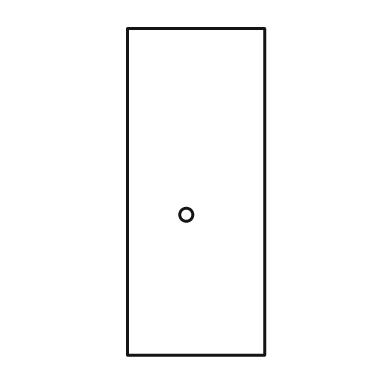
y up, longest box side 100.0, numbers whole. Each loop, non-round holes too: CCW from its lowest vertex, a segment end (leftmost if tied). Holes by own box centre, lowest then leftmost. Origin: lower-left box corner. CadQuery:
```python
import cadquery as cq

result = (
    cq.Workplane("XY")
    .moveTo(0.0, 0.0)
    .lineTo(42.0, 0.0)
    .lineTo(42.0, 100.0)
    .lineTo(0.0, 100.0)
    .close()
    .moveTo(18.0, 43.0)
    .circle(2.0)
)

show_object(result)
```